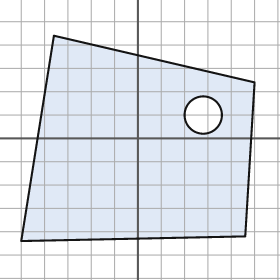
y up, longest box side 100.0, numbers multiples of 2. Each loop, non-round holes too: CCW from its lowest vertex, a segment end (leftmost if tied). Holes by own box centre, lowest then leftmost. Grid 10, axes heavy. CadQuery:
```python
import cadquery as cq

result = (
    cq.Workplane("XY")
    .moveTo(-50.0, -44.0)
    .lineTo(46.0, -42.0)
    .lineTo(50.0, 24.0)
    .lineTo(-36.0, 44.0)
    .close()
    .moveTo(28.0, 10.0)
    .circle(8.0)
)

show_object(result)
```